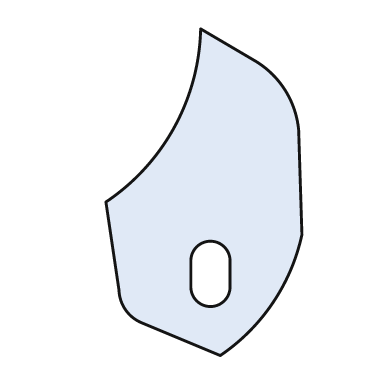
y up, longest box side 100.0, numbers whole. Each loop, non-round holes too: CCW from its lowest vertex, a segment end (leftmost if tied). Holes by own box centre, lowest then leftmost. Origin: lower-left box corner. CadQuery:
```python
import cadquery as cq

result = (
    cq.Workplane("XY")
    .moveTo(35.0, 0.0)
    .threePointArc((51.0, 16.0), (60.0, 37.0))
    .lineTo(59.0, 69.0)
    .threePointArc((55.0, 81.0), (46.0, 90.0))
    .lineTo(29.0, 100.0)
    .threePointArc((21.0, 70.0), (0.0, 47.0))
    .lineTo(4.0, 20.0)
    .threePointArc((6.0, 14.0), (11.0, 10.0))
    .close()
    .moveTo(26.0, 21.0)
    .threePointArc((32.0, 15.0), (38.0, 21.0))
    .lineTo(38.0, 29.0)
    .threePointArc((32.0, 35.0), (26.0, 29.0))
    .close()
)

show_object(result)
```